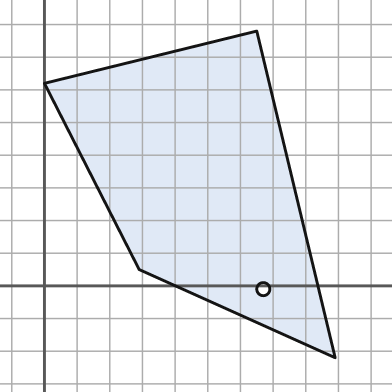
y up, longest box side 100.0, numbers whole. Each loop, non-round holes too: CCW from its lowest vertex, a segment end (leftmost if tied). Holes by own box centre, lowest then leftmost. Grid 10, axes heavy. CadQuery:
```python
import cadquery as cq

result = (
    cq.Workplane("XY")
    .moveTo(89.0, -22.0)
    .lineTo(65.0, 78.0)
    .lineTo(0.0, 62.0)
    .lineTo(29.0, 5.0)
    .close()
    .moveTo(67.0, -1.0)
    .circle(2.0)
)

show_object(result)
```